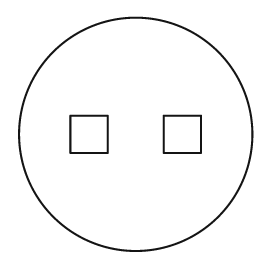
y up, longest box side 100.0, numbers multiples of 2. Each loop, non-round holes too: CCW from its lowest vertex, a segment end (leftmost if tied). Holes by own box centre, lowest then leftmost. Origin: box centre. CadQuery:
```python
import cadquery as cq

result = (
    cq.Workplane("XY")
    .moveTo(0.0, 0.0)
    .circle(50.0)
    .moveTo(-28.0, -8.0)
    .lineTo(-12.0, -8.0)
    .lineTo(-12.0, 8.0)
    .lineTo(-28.0, 8.0)
    .close()
    .moveTo(12.0, -8.0)
    .lineTo(28.0, -8.0)
    .lineTo(28.0, 8.0)
    .lineTo(12.0, 8.0)
    .close()
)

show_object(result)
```